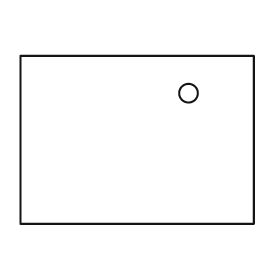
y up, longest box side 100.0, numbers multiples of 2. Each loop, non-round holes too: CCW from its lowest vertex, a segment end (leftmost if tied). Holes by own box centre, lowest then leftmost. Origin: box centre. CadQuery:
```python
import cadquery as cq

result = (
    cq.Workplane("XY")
    .moveTo(-50.0, -36.0)
    .lineTo(50.0, -36.0)
    .lineTo(50.0, 36.0)
    .lineTo(-50.0, 36.0)
    .close()
    .moveTo(22.0, 20.0)
    .circle(4.0)
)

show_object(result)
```